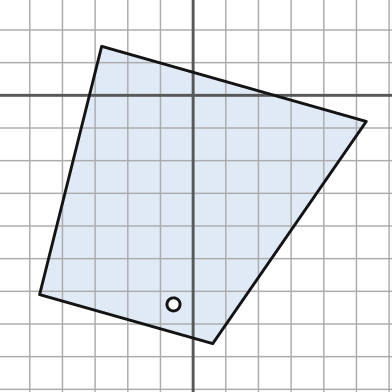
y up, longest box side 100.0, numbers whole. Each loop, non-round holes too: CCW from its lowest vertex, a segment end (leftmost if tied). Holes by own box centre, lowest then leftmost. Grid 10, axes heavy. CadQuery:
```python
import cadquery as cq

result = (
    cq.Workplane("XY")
    .moveTo(6.0, -76.0)
    .lineTo(53.0, -8.0)
    .lineTo(-28.0, 15.0)
    .lineTo(-47.0, -61.0)
    .close()
    .moveTo(-6.0, -64.0)
    .circle(2.0)
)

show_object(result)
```